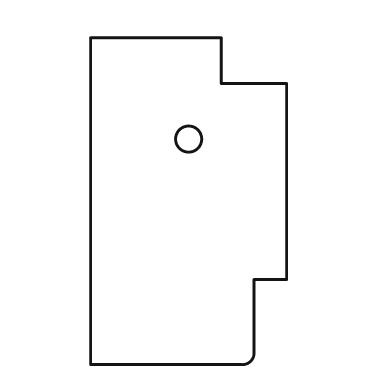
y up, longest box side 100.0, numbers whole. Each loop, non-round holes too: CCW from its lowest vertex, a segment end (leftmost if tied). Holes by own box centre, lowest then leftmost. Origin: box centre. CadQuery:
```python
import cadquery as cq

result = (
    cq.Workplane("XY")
    .moveTo(-30.0, -50.0)
    .lineTo(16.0, -50.0)
    .threePointArc((19.0, -49.0), (20.0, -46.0))
    .lineTo(20.0, -24.0)
    .lineTo(30.0, -24.0)
    .lineTo(30.0, 36.0)
    .lineTo(10.0, 36.0)
    .lineTo(10.0, 50.0)
    .lineTo(-30.0, 50.0)
    .close()
    .moveTo(0.0, 19.0)
    .circle(4.0)
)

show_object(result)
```